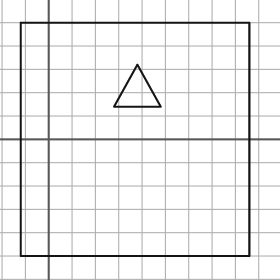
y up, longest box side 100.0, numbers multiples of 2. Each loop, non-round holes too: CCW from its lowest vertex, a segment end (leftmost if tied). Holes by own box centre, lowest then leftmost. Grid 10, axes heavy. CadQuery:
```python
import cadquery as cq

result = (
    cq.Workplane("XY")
    .moveTo(-12.0, -50.0)
    .lineTo(86.0, -50.0)
    .lineTo(86.0, 50.0)
    .lineTo(-12.0, 50.0)
    .close()
    .moveTo(28.0, 14.0)
    .lineTo(48.0, 14.0)
    .lineTo(38.0, 32.0)
    .close()
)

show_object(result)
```